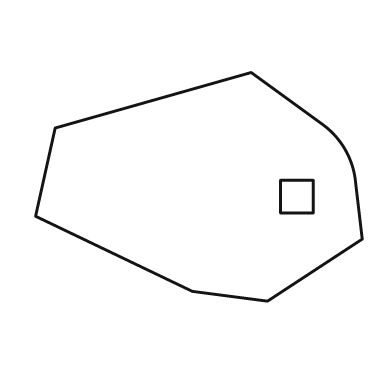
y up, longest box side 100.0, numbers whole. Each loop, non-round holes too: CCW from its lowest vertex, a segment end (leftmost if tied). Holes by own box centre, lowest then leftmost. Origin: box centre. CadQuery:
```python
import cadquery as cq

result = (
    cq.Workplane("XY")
    .moveTo(21.0, -35.0)
    .lineTo(50.0, -16.0)
    .lineTo(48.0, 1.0)
    .threePointArc((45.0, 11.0), (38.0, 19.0))
    .lineTo(16.0, 35.0)
    .lineTo(-44.0, 18.0)
    .lineTo(-50.0, -9.0)
    .lineTo(-2.0, -32.0)
    .close()
    .moveTo(25.0, -8.0)
    .lineTo(35.0, -8.0)
    .lineTo(35.0, 2.0)
    .lineTo(25.0, 2.0)
    .close()
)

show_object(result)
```